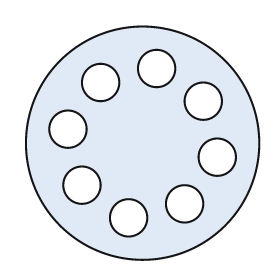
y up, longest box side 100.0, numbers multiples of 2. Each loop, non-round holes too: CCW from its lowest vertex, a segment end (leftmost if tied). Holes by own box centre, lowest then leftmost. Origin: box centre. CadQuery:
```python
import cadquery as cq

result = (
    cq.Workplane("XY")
    .moveTo(0.0, 0.0)
    .circle(50.0)
    .moveTo(-6.0, -32.0)
    .circle(8.0)
    .moveTo(18.0, -26.0)
    .circle(8.0)
    .moveTo(-26.0, -18.0)
    .circle(8.0)
    .moveTo(32.0, -6.0)
    .circle(8.0)
    .moveTo(-32.0, 6.0)
    .circle(8.0)
    .moveTo(26.0, 18.0)
    .circle(8.0)
    .moveTo(-18.0, 26.0)
    .circle(8.0)
    .moveTo(6.0, 32.0)
    .circle(8.0)
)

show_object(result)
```